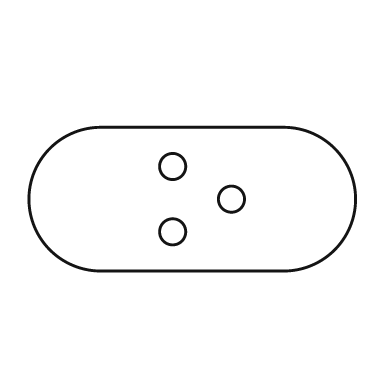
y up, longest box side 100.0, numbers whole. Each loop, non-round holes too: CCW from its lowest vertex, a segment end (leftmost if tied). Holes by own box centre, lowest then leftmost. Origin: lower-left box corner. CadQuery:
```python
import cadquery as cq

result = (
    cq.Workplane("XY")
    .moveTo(22.0, 0.0)
    .lineTo(78.0, 0.0)
    .threePointArc((100.0, 22.0), (78.0, 44.0))
    .lineTo(22.0, 44.0)
    .threePointArc((0.0, 22.0), (22.0, 0.0))
    .close()
    .moveTo(44.0, 12.0)
    .circle(4.0)
    .moveTo(62.0, 22.0)
    .circle(4.0)
    .moveTo(44.0, 32.0)
    .circle(4.0)
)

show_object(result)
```